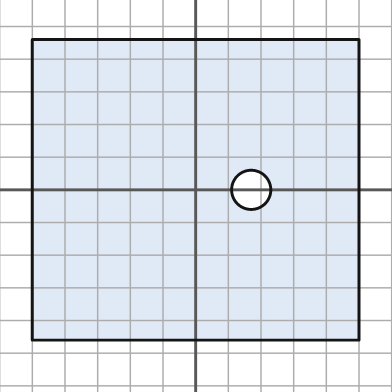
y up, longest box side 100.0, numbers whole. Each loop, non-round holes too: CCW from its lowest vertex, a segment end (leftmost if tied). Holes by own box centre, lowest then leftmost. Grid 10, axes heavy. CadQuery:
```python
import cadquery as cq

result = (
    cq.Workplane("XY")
    .moveTo(-50.0, -46.0)
    .lineTo(50.0, -46.0)
    .lineTo(50.0, 46.0)
    .lineTo(-50.0, 46.0)
    .close()
    .moveTo(17.0, 0.0)
    .circle(6.0)
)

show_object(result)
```